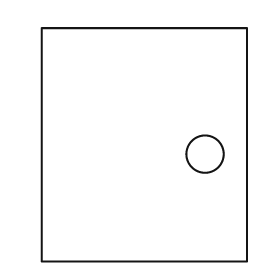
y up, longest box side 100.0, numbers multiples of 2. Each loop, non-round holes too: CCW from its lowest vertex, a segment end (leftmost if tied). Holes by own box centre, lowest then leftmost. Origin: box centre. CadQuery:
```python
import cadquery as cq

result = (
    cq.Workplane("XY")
    .moveTo(-44.0, -50.0)
    .lineTo(44.0, -50.0)
    .lineTo(44.0, 50.0)
    .lineTo(-44.0, 50.0)
    .close()
    .moveTo(26.0, -4.0)
    .circle(8.0)
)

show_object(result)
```